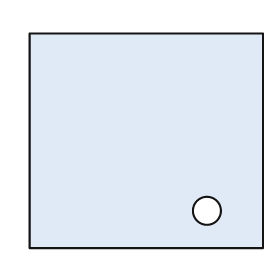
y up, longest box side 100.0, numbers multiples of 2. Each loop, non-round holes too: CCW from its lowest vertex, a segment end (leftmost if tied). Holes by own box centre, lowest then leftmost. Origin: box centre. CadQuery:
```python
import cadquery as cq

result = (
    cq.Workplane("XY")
    .moveTo(-50.0, -46.0)
    .lineTo(50.0, -46.0)
    .lineTo(50.0, 46.0)
    .lineTo(-50.0, 46.0)
    .close()
    .moveTo(26.0, -30.0)
    .circle(6.0)
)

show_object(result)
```